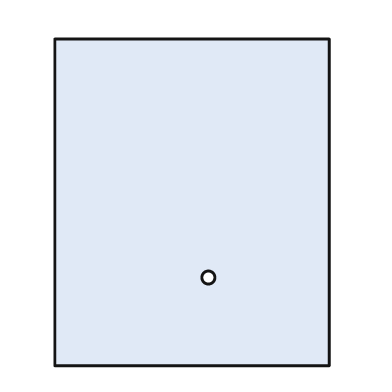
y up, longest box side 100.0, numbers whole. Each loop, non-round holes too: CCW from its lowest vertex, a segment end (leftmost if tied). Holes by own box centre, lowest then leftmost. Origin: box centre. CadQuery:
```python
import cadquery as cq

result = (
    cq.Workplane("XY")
    .moveTo(-42.0, -50.0)
    .lineTo(42.0, -50.0)
    .lineTo(42.0, 50.0)
    .lineTo(-42.0, 50.0)
    .close()
    .moveTo(5.0, -23.0)
    .circle(2.0)
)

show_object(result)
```